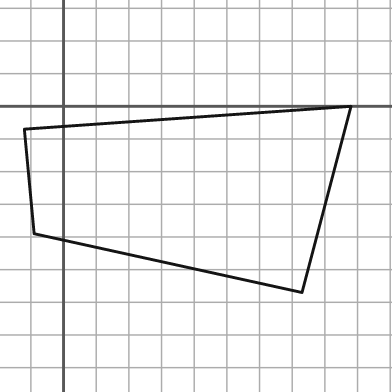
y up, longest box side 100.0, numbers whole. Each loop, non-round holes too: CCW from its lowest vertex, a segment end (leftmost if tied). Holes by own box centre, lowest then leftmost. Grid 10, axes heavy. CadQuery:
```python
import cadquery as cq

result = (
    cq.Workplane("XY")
    .moveTo(73.0, -57.0)
    .lineTo(88.0, 0.0)
    .lineTo(-12.0, -7.0)
    .lineTo(-9.0, -39.0)
    .close()
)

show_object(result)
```